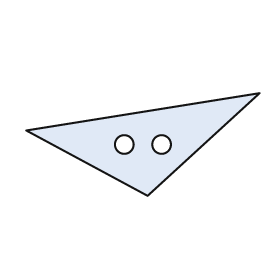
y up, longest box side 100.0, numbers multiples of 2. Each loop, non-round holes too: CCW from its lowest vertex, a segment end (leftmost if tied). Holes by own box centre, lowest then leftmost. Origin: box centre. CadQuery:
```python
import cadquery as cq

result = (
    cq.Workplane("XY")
    .moveTo(2.0, -22.0)
    .lineTo(50.0, 22.0)
    .lineTo(-50.0, 6.0)
    .close()
    .moveTo(-8.0, 0.0)
    .circle(4.0)
    .moveTo(8.0, 0.0)
    .circle(4.0)
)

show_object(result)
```